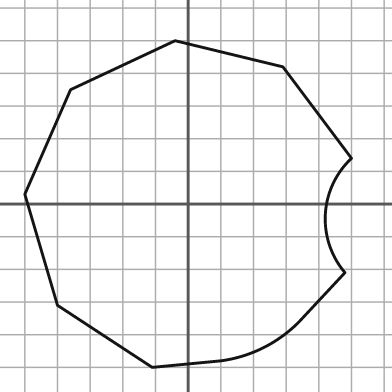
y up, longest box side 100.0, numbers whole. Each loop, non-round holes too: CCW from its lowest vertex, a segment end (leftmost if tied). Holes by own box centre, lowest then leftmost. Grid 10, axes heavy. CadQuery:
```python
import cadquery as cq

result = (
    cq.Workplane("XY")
    .moveTo(-11.0, -50.0)
    .lineTo(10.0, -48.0)
    .threePointArc((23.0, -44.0), (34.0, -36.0))
    .lineTo(48.0, -21.0)
    .threePointArc((42.0, -3.0), (50.0, 14.0))
    .lineTo(29.0, 42.0)
    .lineTo(-4.0, 50.0)
    .lineTo(-36.0, 35.0)
    .lineTo(-50.0, 3.0)
    .lineTo(-40.0, -31.0)
    .close()
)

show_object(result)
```